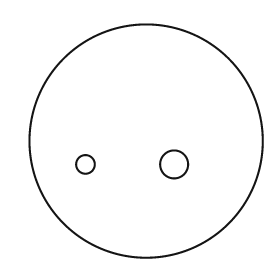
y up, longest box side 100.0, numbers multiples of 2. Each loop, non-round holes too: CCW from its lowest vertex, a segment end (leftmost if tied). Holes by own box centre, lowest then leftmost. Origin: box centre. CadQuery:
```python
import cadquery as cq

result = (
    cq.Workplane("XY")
    .moveTo(0.0, 0.0)
    .circle(50.0)
    .moveTo(-26.0, -10.0)
    .circle(4.0)
    .moveTo(12.0, -10.0)
    .circle(6.0)
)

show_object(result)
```